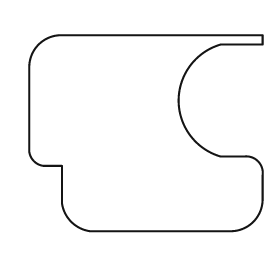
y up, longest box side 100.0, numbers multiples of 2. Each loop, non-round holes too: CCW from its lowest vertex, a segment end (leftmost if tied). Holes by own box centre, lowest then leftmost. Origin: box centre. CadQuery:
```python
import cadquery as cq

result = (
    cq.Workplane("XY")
    .moveTo(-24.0, -42.0)
    .lineTo(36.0, -42.0)
    .threePointArc((46.0, -38.0), (50.0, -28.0))
    .lineTo(50.0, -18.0)
    .threePointArc((48.0, -12.0), (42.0, -10.0))
    .lineTo(32.0, -10.0)
    .threePointArc((14.0, 14.0), (32.0, 38.0))
    .lineTo(50.0, 38.0)
    .lineTo(50.0, 42.0)
    .lineTo(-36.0, 42.0)
    .threePointArc((-46.0, 38.0), (-50.0, 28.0))
    .lineTo(-50.0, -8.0)
    .threePointArc((-48.0, -12.0), (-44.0, -14.0))
    .lineTo(-36.0, -14.0)
    .lineTo(-36.0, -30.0)
    .threePointArc((-32.0, -38.0), (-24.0, -42.0))
    .close()
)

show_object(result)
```